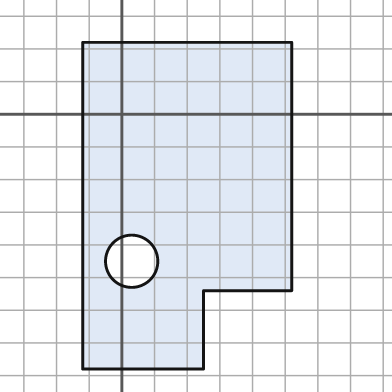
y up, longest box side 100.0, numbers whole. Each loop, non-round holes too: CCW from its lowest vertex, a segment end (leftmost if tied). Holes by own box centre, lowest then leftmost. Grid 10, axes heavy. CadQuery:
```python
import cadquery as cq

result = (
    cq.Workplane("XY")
    .moveTo(-12.0, -78.0)
    .lineTo(25.0, -78.0)
    .lineTo(25.0, -54.0)
    .lineTo(52.0, -54.0)
    .lineTo(52.0, 22.0)
    .lineTo(-12.0, 22.0)
    .close()
    .moveTo(3.0, -45.0)
    .circle(8.0)
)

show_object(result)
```